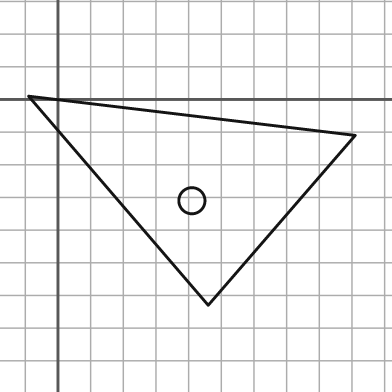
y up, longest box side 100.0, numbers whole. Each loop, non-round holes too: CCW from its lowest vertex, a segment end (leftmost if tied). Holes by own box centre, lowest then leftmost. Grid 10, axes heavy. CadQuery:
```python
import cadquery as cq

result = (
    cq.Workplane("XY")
    .moveTo(46.0, -63.0)
    .lineTo(91.0, -11.0)
    .lineTo(-9.0, 1.0)
    .close()
    .moveTo(41.0, -31.0)
    .circle(4.0)
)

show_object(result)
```